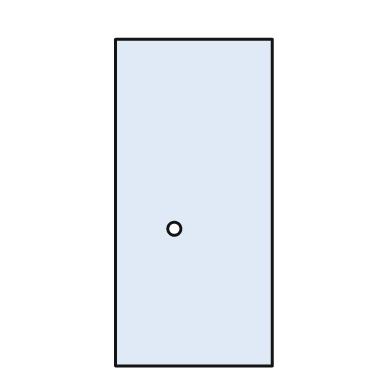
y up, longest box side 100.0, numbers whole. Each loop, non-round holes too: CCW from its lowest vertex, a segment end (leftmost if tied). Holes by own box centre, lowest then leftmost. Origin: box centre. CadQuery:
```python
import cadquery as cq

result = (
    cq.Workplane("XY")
    .moveTo(-24.0, -50.0)
    .lineTo(24.0, -50.0)
    .lineTo(24.0, 50.0)
    .lineTo(-24.0, 50.0)
    .close()
    .moveTo(-6.0, -8.0)
    .circle(2.0)
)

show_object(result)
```